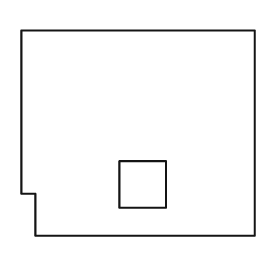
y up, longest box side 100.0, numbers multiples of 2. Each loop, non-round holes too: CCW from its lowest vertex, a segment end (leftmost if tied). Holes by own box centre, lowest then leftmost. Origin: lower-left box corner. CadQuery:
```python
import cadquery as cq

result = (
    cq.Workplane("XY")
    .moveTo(6.0, 0.0)
    .lineTo(100.0, 0.0)
    .lineTo(100.0, 88.0)
    .lineTo(0.0, 88.0)
    .lineTo(0.0, 18.0)
    .lineTo(6.0, 18.0)
    .close()
    .moveTo(42.0, 12.0)
    .lineTo(62.0, 12.0)
    .lineTo(62.0, 32.0)
    .lineTo(42.0, 32.0)
    .close()
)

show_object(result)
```